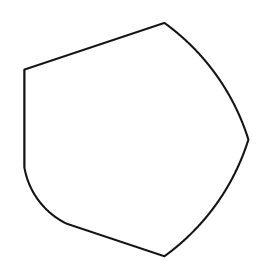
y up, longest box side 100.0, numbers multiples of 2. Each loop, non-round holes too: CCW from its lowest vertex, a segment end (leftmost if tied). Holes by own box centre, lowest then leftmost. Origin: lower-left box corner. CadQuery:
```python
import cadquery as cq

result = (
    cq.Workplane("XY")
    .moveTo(60.0, 0.0)
    .threePointArc((82.0, 22.0), (96.0, 50.0))
    .threePointArc((82.0, 78.0), (60.0, 100.0))
    .lineTo(0.0, 80.0)
    .lineTo(0.0, 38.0)
    .threePointArc((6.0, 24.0), (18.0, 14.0))
    .close()
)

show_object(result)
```